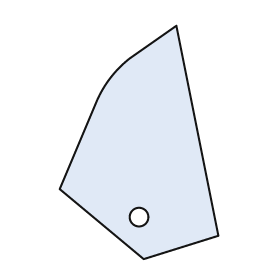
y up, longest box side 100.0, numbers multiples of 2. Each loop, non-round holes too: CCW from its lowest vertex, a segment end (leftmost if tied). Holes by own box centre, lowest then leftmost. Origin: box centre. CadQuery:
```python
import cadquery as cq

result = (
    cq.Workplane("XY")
    .moveTo(2.0, -50.0)
    .lineTo(34.0, -40.0)
    .lineTo(16.0, 50.0)
    .lineTo(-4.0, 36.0)
    .threePointArc((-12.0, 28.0), (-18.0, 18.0))
    .lineTo(-34.0, -20.0)
    .close()
    .moveTo(0.0, -32.0)
    .circle(4.0)
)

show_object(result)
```